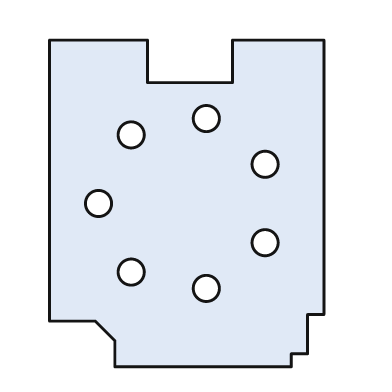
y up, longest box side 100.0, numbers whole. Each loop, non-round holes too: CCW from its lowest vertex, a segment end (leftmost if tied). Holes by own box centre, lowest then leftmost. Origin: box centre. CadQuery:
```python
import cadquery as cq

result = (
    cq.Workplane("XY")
    .moveTo(-22.0, -50.0)
    .lineTo(32.0, -50.0)
    .lineTo(32.0, -46.0)
    .lineTo(37.0, -46.0)
    .lineTo(37.0, -34.0)
    .lineTo(42.0, -34.0)
    .lineTo(42.0, 50.0)
    .lineTo(14.0, 50.0)
    .lineTo(14.0, 37.0)
    .lineTo(-12.0, 37.0)
    .lineTo(-12.0, 50.0)
    .lineTo(-42.0, 50.0)
    .lineTo(-42.0, -36.0)
    .lineTo(-28.0, -36.0)
    .lineTo(-22.0, -42.0)
    .close()
    .moveTo(6.0, -26.0)
    .circle(4.0)
    .moveTo(-17.0, -21.0)
    .circle(4.0)
    .moveTo(24.0, -12.0)
    .circle(4.0)
    .moveTo(-27.0, 0.0)
    .circle(4.0)
    .moveTo(24.0, 12.0)
    .circle(4.0)
    .moveTo(-17.0, 21.0)
    .circle(4.0)
    .moveTo(6.0, 26.0)
    .circle(4.0)
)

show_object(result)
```